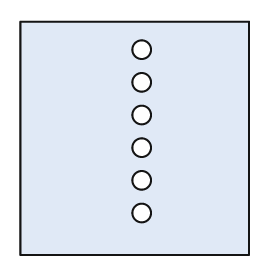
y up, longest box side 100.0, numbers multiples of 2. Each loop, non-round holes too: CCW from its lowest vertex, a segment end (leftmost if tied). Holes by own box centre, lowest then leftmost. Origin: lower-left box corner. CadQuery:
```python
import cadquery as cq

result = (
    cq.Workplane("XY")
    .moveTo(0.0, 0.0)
    .lineTo(98.0, 0.0)
    .lineTo(98.0, 100.0)
    .lineTo(0.0, 100.0)
    .close()
    .moveTo(52.0, 18.0)
    .circle(4.0)
    .moveTo(52.0, 32.0)
    .circle(4.0)
    .moveTo(52.0, 46.0)
    .circle(4.0)
    .moveTo(52.0, 60.0)
    .circle(4.0)
    .moveTo(52.0, 74.0)
    .circle(4.0)
    .moveTo(52.0, 88.0)
    .circle(4.0)
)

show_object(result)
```